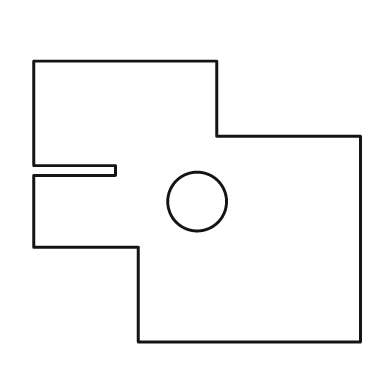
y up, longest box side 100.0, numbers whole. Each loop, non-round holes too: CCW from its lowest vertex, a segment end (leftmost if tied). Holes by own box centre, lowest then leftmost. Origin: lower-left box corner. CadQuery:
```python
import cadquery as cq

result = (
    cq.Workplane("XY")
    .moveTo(32.0, 0.0)
    .lineTo(100.0, 0.0)
    .lineTo(100.0, 63.0)
    .lineTo(56.0, 63.0)
    .lineTo(56.0, 86.0)
    .lineTo(0.0, 86.0)
    .lineTo(0.0, 54.0)
    .lineTo(25.0, 54.0)
    .lineTo(25.0, 51.0)
    .lineTo(0.0, 51.0)
    .lineTo(0.0, 29.0)
    .lineTo(32.0, 29.0)
    .close()
    .moveTo(50.0, 43.0)
    .circle(9.0)
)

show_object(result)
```